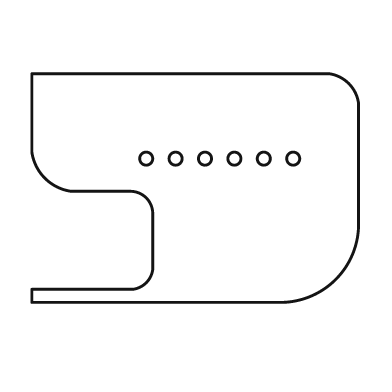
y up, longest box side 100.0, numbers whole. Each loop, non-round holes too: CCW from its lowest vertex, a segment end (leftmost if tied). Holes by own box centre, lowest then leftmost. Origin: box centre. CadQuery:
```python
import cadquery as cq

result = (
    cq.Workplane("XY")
    .moveTo(-50.0, -35.0)
    .lineTo(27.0, -35.0)
    .threePointArc((43.0, -28.0), (50.0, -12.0))
    .lineTo(50.0, 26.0)
    .threePointArc((47.0, 32.0), (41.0, 35.0))
    .lineTo(-50.0, 35.0)
    .lineTo(-50.0, 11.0)
    .threePointArc((-46.0, 3.0), (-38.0, -1.0))
    .lineTo(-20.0, -1.0)
    .threePointArc((-15.0, -3.0), (-13.0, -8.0))
    .lineTo(-13.0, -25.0)
    .threePointArc((-15.0, -29.0), (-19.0, -31.0))
    .lineTo(-50.0, -31.0)
    .close()
    .moveTo(-15.0, 9.0)
    .circle(2.0)
    .moveTo(-6.0, 9.0)
    .circle(2.0)
    .moveTo(3.0, 9.0)
    .circle(2.0)
    .moveTo(12.0, 9.0)
    .circle(2.0)
    .moveTo(21.0, 9.0)
    .circle(2.0)
    .moveTo(30.0, 9.0)
    .circle(2.0)
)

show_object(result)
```